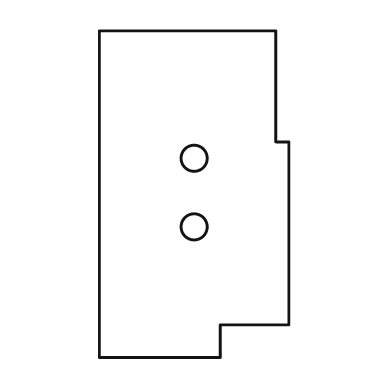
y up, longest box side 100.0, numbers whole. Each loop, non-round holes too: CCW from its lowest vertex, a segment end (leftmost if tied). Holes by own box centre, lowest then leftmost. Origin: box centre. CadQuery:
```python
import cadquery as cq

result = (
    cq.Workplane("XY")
    .moveTo(-29.0, -50.0)
    .lineTo(8.0, -50.0)
    .lineTo(8.0, -40.0)
    .lineTo(29.0, -40.0)
    .lineTo(29.0, 16.0)
    .lineTo(25.0, 16.0)
    .lineTo(25.0, 50.0)
    .lineTo(-29.0, 50.0)
    .close()
    .moveTo(0.0, -10.0)
    .circle(4.0)
    .moveTo(0.0, 11.0)
    .circle(4.0)
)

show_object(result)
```